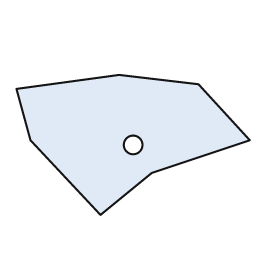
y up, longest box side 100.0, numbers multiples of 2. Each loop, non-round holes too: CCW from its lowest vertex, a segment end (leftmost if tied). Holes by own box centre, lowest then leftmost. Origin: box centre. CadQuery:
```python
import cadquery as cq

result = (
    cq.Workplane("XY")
    .moveTo(-14.0, -30.0)
    .lineTo(8.0, -12.0)
    .lineTo(50.0, 2.0)
    .lineTo(28.0, 26.0)
    .lineTo(-6.0, 30.0)
    .lineTo(-50.0, 24.0)
    .lineTo(-44.0, 2.0)
    .close()
    .moveTo(0.0, 0.0)
    .circle(4.0)
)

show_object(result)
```